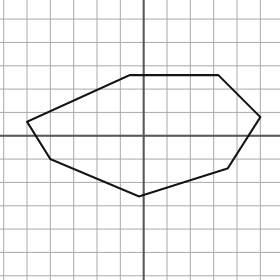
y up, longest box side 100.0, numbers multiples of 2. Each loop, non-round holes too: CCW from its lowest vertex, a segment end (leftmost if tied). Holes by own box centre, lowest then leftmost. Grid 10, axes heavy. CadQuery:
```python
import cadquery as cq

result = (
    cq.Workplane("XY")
    .moveTo(-2.0, -26.0)
    .lineTo(36.0, -14.0)
    .lineTo(50.0, 8.0)
    .lineTo(32.0, 26.0)
    .lineTo(-6.0, 26.0)
    .lineTo(-50.0, 6.0)
    .lineTo(-40.0, -10.0)
    .close()
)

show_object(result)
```